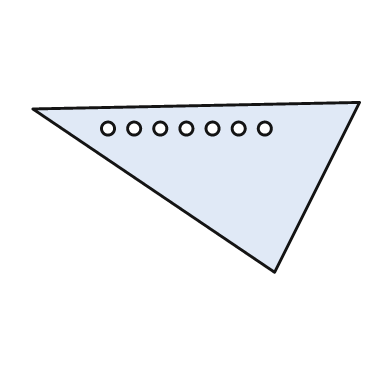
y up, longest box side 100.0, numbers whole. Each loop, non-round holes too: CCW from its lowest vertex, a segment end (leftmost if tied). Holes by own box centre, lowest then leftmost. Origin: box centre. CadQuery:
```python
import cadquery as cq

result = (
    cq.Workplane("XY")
    .moveTo(24.0, -26.0)
    .lineTo(50.0, 26.0)
    .lineTo(-50.0, 24.0)
    .close()
    .moveTo(-27.0, 18.0)
    .circle(2.0)
    .moveTo(-19.0, 18.0)
    .circle(2.0)
    .moveTo(-11.0, 18.0)
    .circle(2.0)
    .moveTo(-3.0, 18.0)
    .circle(2.0)
    .moveTo(5.0, 18.0)
    .circle(2.0)
    .moveTo(13.0, 18.0)
    .circle(2.0)
    .moveTo(21.0, 18.0)
    .circle(2.0)
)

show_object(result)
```